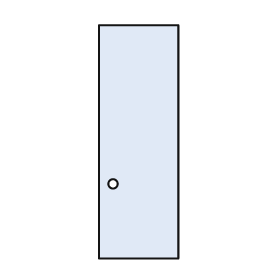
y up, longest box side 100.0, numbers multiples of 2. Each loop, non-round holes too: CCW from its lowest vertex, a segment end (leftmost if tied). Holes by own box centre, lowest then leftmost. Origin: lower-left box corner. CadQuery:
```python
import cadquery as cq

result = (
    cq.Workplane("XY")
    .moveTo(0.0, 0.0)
    .lineTo(34.0, 0.0)
    .lineTo(34.0, 100.0)
    .lineTo(0.0, 100.0)
    .close()
    .moveTo(6.0, 32.0)
    .circle(2.0)
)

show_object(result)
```